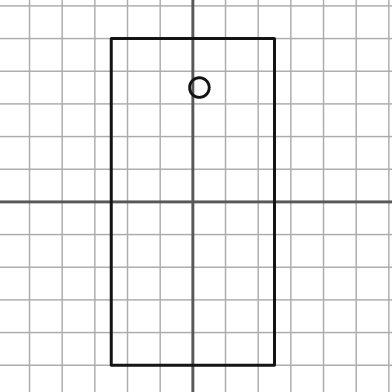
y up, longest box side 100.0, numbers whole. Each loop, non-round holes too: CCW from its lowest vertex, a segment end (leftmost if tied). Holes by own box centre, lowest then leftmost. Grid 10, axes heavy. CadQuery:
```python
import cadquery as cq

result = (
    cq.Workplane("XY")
    .moveTo(-25.0, -50.0)
    .lineTo(25.0, -50.0)
    .lineTo(25.0, 50.0)
    .lineTo(-25.0, 50.0)
    .close()
    .moveTo(2.0, 35.0)
    .circle(3.0)
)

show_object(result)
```